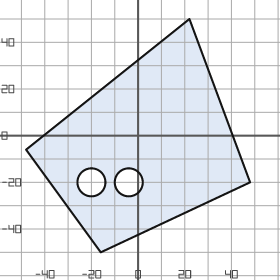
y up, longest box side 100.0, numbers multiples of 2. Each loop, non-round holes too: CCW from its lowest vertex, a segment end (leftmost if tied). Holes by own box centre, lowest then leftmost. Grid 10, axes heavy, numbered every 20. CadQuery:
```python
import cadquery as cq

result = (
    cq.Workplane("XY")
    .moveTo(-16.0, -50.0)
    .lineTo(48.0, -20.0)
    .lineTo(22.0, 50.0)
    .lineTo(-48.0, -6.0)
    .close()
    .moveTo(-20.0, -20.0)
    .circle(6.0)
    .moveTo(-4.0, -20.0)
    .circle(6.0)
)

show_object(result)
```